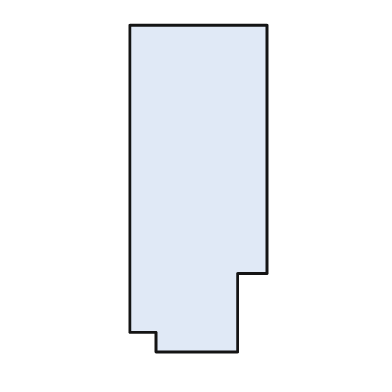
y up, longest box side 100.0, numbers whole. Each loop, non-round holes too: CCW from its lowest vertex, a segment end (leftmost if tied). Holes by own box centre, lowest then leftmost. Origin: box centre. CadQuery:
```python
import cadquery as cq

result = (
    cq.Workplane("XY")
    .moveTo(-13.0, -50.0)
    .lineTo(12.0, -50.0)
    .lineTo(12.0, -26.0)
    .lineTo(21.0, -26.0)
    .lineTo(21.0, 50.0)
    .lineTo(-21.0, 50.0)
    .lineTo(-21.0, -44.0)
    .lineTo(-13.0, -44.0)
    .close()
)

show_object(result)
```